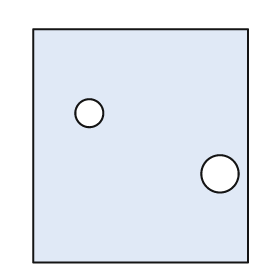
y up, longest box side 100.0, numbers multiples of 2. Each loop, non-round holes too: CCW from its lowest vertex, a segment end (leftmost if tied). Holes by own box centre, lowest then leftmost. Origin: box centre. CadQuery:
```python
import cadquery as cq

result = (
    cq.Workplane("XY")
    .moveTo(-46.0, -50.0)
    .lineTo(46.0, -50.0)
    .lineTo(46.0, 50.0)
    .lineTo(-46.0, 50.0)
    .close()
    .moveTo(34.0, -12.0)
    .circle(8.0)
    .moveTo(-22.0, 14.0)
    .circle(6.0)
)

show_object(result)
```